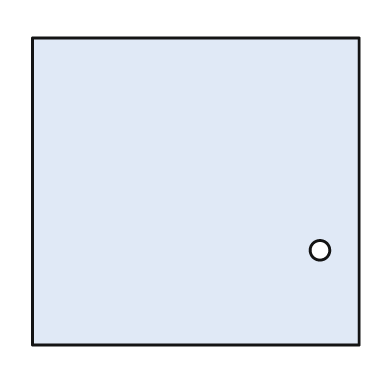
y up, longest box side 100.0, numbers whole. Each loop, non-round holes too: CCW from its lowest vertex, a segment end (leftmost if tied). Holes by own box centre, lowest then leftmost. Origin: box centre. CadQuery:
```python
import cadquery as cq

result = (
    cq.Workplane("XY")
    .moveTo(-50.0, -47.0)
    .lineTo(50.0, -47.0)
    .lineTo(50.0, 47.0)
    .lineTo(-50.0, 47.0)
    .close()
    .moveTo(38.0, -18.0)
    .circle(3.0)
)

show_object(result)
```